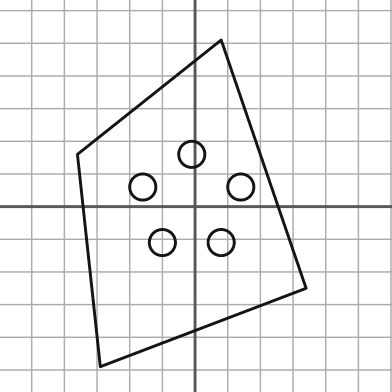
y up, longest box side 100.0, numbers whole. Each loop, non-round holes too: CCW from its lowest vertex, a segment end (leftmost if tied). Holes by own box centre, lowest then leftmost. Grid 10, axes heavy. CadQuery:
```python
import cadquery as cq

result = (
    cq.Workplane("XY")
    .moveTo(-29.0, -49.0)
    .lineTo(34.0, -25.0)
    .lineTo(8.0, 51.0)
    .lineTo(-36.0, 16.0)
    .close()
    .moveTo(-10.0, -11.0)
    .circle(4.0)
    .moveTo(8.0, -11.0)
    .circle(4.0)
    .moveTo(-16.0, 6.0)
    .circle(4.0)
    .moveTo(14.0, 6.0)
    .circle(4.0)
    .moveTo(-1.0, 16.0)
    .circle(4.0)
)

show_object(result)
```